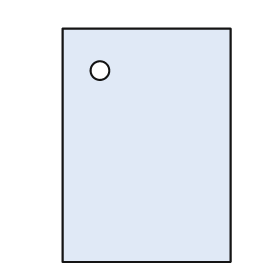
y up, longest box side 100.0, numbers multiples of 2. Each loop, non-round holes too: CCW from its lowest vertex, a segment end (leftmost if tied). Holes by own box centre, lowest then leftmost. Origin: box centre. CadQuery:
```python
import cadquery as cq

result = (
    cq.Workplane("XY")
    .moveTo(-36.0, -50.0)
    .lineTo(36.0, -50.0)
    .lineTo(36.0, 50.0)
    .lineTo(-36.0, 50.0)
    .close()
    .moveTo(-20.0, 32.0)
    .circle(4.0)
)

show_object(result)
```